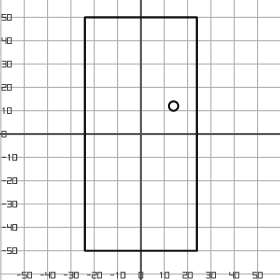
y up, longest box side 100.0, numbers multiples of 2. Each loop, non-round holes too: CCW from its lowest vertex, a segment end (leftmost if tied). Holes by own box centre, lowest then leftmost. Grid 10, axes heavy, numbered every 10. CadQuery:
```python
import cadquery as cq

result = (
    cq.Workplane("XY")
    .moveTo(-24.0, -50.0)
    .lineTo(24.0, -50.0)
    .lineTo(24.0, 50.0)
    .lineTo(-24.0, 50.0)
    .close()
    .moveTo(14.0, 12.0)
    .circle(2.0)
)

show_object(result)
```